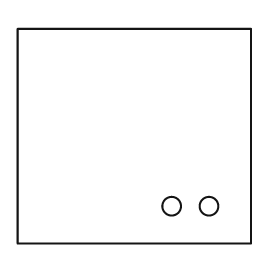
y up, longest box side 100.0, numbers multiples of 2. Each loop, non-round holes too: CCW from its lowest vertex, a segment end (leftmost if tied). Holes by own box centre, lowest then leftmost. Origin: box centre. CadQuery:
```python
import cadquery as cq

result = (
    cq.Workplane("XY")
    .moveTo(-50.0, -46.0)
    .lineTo(50.0, -46.0)
    .lineTo(50.0, 46.0)
    .lineTo(-50.0, 46.0)
    .close()
    .moveTo(16.0, -30.0)
    .circle(4.0)
    .moveTo(32.0, -30.0)
    .circle(4.0)
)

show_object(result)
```